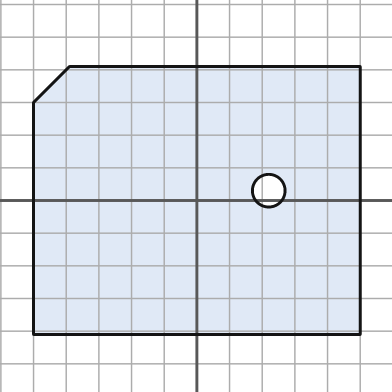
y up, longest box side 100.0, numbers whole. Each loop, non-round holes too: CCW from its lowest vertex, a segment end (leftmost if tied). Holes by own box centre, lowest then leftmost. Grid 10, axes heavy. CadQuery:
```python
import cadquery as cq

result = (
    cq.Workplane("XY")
    .moveTo(-50.0, -41.0)
    .lineTo(50.0, -41.0)
    .lineTo(50.0, 41.0)
    .lineTo(-39.0, 41.0)
    .lineTo(-50.0, 30.0)
    .close()
    .moveTo(22.0, 3.0)
    .circle(5.0)
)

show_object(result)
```